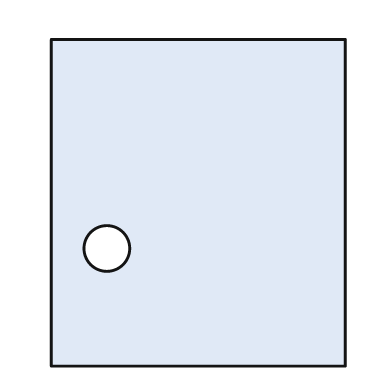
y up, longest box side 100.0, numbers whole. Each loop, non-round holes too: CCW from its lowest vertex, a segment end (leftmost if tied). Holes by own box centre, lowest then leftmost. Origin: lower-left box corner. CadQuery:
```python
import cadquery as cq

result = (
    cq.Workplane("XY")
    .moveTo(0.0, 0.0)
    .lineTo(90.0, 0.0)
    .lineTo(90.0, 100.0)
    .lineTo(0.0, 100.0)
    .close()
    .moveTo(17.0, 36.0)
    .circle(7.0)
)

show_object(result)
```